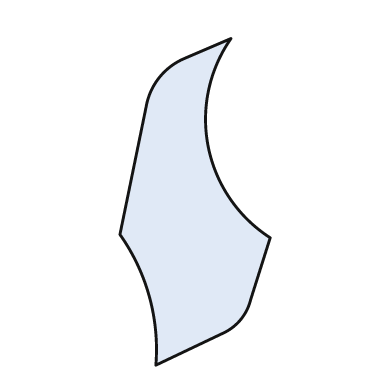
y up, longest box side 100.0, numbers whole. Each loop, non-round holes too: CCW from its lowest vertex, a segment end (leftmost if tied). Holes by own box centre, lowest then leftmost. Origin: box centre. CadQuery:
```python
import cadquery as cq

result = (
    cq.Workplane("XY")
    .moveTo(-12.0, -50.0)
    .lineTo(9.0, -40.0)
    .threePointArc((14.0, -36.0), (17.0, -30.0))
    .lineTo(23.0, -11.0)
    .threePointArc((4.0, 17.0), (11.0, 50.0))
    .lineTo(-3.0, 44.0)
    .threePointArc((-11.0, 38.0), (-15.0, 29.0))
    .lineTo(-23.0, -10.0)
    .threePointArc((-14.0, -29.0), (-12.0, -50.0))
    .close()
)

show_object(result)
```